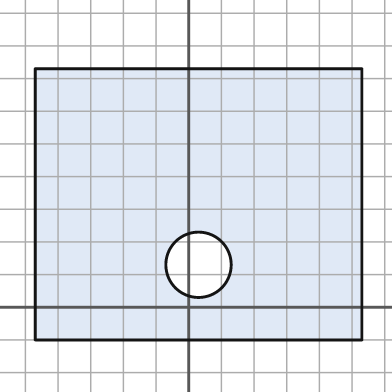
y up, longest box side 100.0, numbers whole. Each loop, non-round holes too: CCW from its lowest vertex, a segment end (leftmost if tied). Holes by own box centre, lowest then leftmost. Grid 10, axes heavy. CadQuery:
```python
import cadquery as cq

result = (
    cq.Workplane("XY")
    .moveTo(-47.0, -10.0)
    .lineTo(53.0, -10.0)
    .lineTo(53.0, 73.0)
    .lineTo(-47.0, 73.0)
    .close()
    .moveTo(3.0, 13.0)
    .circle(10.0)
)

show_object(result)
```